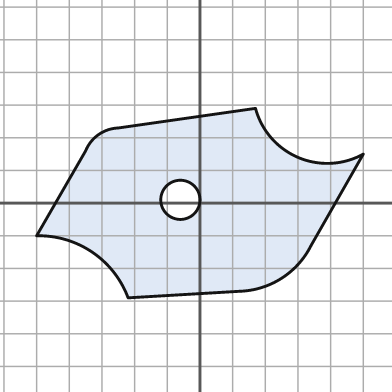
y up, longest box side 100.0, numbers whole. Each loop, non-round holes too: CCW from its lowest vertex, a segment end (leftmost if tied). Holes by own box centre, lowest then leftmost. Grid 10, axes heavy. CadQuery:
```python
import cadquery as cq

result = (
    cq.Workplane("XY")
    .moveTo(-22.0, -29.0)
    .lineTo(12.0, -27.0)
    .threePointArc((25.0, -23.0), (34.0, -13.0))
    .lineTo(50.0, 15.0)
    .threePointArc((30.0, 14.0), (17.0, 29.0))
    .lineTo(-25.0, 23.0)
    .threePointArc((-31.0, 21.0), (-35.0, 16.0))
    .lineTo(-50.0, -10.0)
    .threePointArc((-33.0, -15.0), (-22.0, -29.0))
    .close()
    .moveTo(-6.0, 1.0)
    .circle(6.0)
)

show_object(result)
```